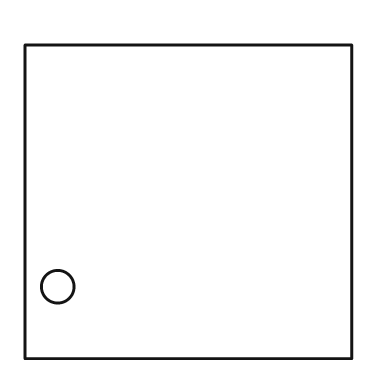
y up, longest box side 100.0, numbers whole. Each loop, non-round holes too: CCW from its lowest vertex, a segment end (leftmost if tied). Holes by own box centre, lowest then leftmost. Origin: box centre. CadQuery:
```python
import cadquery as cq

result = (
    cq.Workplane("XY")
    .moveTo(-50.0, -48.0)
    .lineTo(50.0, -48.0)
    .lineTo(50.0, 48.0)
    .lineTo(-50.0, 48.0)
    .close()
    .moveTo(-40.0, -26.0)
    .circle(5.0)
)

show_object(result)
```